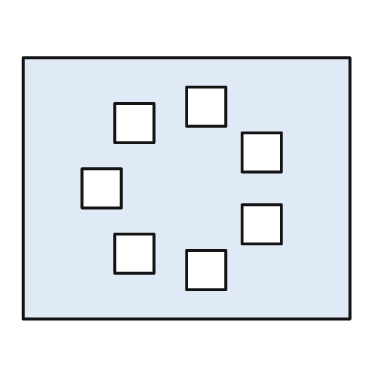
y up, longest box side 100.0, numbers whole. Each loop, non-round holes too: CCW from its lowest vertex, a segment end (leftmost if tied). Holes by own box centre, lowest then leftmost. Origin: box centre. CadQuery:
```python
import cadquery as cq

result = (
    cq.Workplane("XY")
    .moveTo(-50.0, -40.0)
    .lineTo(50.0, -40.0)
    .lineTo(50.0, 40.0)
    .lineTo(-50.0, 40.0)
    .close()
    .moveTo(0.0, -31.0)
    .lineTo(12.0, -31.0)
    .lineTo(12.0, -19.0)
    .lineTo(0.0, -19.0)
    .close()
    .moveTo(-22.0, -26.0)
    .lineTo(-10.0, -26.0)
    .lineTo(-10.0, -14.0)
    .lineTo(-22.0, -14.0)
    .close()
    .moveTo(17.0, -17.0)
    .lineTo(29.0, -17.0)
    .lineTo(29.0, -5.0)
    .lineTo(17.0, -5.0)
    .close()
    .moveTo(-32.0, -6.0)
    .lineTo(-20.0, -6.0)
    .lineTo(-20.0, 6.0)
    .lineTo(-32.0, 6.0)
    .close()
    .moveTo(17.0, 5.0)
    .lineTo(29.0, 5.0)
    .lineTo(29.0, 17.0)
    .lineTo(17.0, 17.0)
    .close()
    .moveTo(-22.0, 14.0)
    .lineTo(-10.0, 14.0)
    .lineTo(-10.0, 26.0)
    .lineTo(-22.0, 26.0)
    .close()
    .moveTo(0.0, 19.0)
    .lineTo(12.0, 19.0)
    .lineTo(12.0, 31.0)
    .lineTo(0.0, 31.0)
    .close()
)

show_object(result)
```